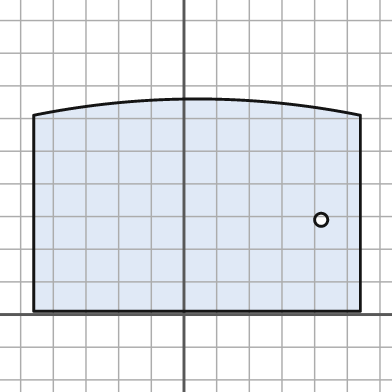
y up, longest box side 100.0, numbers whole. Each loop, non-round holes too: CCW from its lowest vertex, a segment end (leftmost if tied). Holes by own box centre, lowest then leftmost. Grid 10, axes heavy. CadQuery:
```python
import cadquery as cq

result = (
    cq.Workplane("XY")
    .moveTo(-46.0, 1.0)
    .lineTo(54.0, 1.0)
    .lineTo(54.0, 61.0)
    .threePointArc((4.0, 66.0), (-46.0, 61.0))
    .close()
    .moveTo(42.0, 29.0)
    .circle(2.0)
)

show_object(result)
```